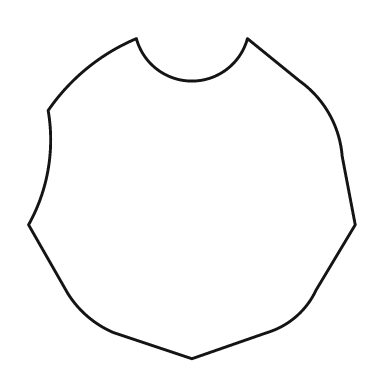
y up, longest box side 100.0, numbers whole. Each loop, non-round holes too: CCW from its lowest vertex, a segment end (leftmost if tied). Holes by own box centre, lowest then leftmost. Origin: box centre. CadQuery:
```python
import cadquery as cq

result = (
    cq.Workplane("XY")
    .moveTo(0.0, -49.0)
    .lineTo(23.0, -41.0)
    .threePointArc((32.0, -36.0), (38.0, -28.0))
    .lineTo(50.0, -8.0)
    .lineTo(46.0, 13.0)
    .threePointArc((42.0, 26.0), (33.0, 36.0))
    .lineTo(17.0, 49.0)
    .threePointArc((0.0, 36.0), (-17.0, 49.0))
    .threePointArc((-32.0, 40.0), (-44.0, 27.0))
    .threePointArc((-44.0, 9.0), (-50.0, -8.0))
    .lineTo(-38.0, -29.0)
    .threePointArc((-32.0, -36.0), (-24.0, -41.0))
    .close()
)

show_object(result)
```